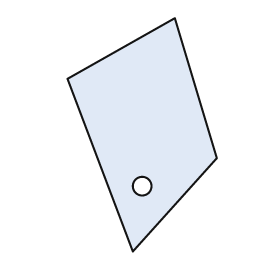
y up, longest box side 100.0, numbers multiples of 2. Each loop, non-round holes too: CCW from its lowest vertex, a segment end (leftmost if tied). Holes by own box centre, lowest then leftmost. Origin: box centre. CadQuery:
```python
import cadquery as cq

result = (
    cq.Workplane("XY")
    .moveTo(-4.0, -50.0)
    .lineTo(32.0, -10.0)
    .lineTo(14.0, 50.0)
    .lineTo(-32.0, 24.0)
    .close()
    .moveTo(0.0, -22.0)
    .circle(4.0)
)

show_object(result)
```